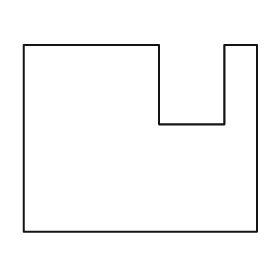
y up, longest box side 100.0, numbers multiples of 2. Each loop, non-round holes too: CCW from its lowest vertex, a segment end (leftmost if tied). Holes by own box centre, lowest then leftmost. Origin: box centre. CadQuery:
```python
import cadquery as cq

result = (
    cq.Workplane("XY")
    .moveTo(-50.0, -40.0)
    .lineTo(50.0, -40.0)
    .lineTo(50.0, 40.0)
    .lineTo(36.0, 40.0)
    .lineTo(36.0, 6.0)
    .lineTo(8.0, 6.0)
    .lineTo(8.0, 40.0)
    .lineTo(-50.0, 40.0)
    .close()
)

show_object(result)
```